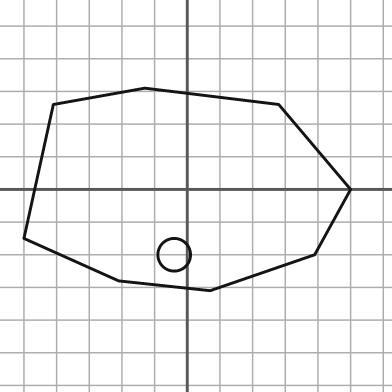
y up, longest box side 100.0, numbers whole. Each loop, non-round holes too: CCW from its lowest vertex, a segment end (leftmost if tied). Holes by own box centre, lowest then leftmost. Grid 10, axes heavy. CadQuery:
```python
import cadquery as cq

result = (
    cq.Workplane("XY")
    .moveTo(7.0, -31.0)
    .lineTo(39.0, -20.0)
    .lineTo(50.0, 0.0)
    .lineTo(28.0, 26.0)
    .lineTo(-13.0, 31.0)
    .lineTo(-41.0, 26.0)
    .lineTo(-50.0, -15.0)
    .lineTo(-21.0, -28.0)
    .close()
    .moveTo(-4.0, -20.0)
    .circle(5.0)
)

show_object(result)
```